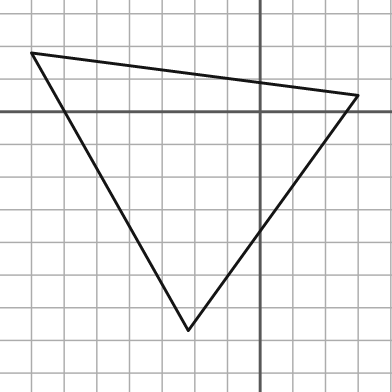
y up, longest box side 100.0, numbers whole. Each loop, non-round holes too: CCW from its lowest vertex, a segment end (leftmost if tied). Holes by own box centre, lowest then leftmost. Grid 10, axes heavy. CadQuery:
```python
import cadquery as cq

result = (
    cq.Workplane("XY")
    .moveTo(-22.0, -67.0)
    .lineTo(30.0, 5.0)
    .lineTo(-70.0, 18.0)
    .close()
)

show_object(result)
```